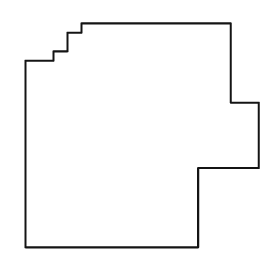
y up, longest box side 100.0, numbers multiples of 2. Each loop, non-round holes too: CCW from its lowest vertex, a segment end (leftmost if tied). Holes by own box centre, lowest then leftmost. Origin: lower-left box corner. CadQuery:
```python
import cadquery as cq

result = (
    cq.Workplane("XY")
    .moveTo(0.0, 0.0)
    .lineTo(74.0, 0.0)
    .lineTo(74.0, 34.0)
    .lineTo(100.0, 34.0)
    .lineTo(100.0, 62.0)
    .lineTo(88.0, 62.0)
    .lineTo(88.0, 96.0)
    .lineTo(24.0, 96.0)
    .lineTo(24.0, 92.0)
    .lineTo(18.0, 92.0)
    .lineTo(18.0, 84.0)
    .lineTo(12.0, 84.0)
    .lineTo(12.0, 80.0)
    .lineTo(0.0, 80.0)
    .close()
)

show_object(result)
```